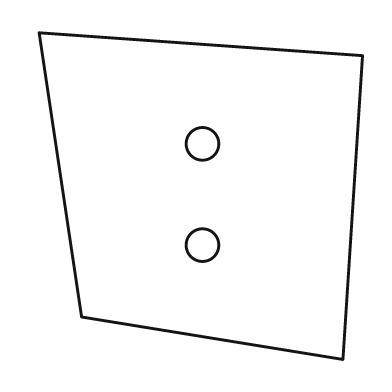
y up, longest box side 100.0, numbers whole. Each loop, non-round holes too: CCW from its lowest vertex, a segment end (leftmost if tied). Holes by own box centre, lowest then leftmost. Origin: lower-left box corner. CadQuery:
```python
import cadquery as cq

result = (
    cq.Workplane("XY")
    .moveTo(93.0, 0.0)
    .lineTo(99.0, 93.0)
    .lineTo(0.0, 100.0)
    .lineTo(13.0, 13.0)
    .close()
    .moveTo(50.0, 35.0)
    .circle(5.0)
    .moveTo(50.0, 66.0)
    .circle(5.0)
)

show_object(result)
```